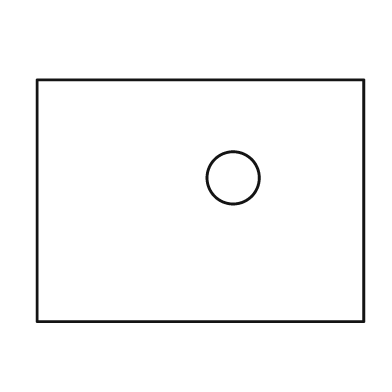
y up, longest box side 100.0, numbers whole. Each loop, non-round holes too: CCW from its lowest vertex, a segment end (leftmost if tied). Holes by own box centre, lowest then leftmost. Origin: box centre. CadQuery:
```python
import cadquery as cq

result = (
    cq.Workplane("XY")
    .moveTo(-50.0, -37.0)
    .lineTo(50.0, -37.0)
    .lineTo(50.0, 37.0)
    .lineTo(-50.0, 37.0)
    .close()
    .moveTo(10.0, 7.0)
    .circle(8.0)
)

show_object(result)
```